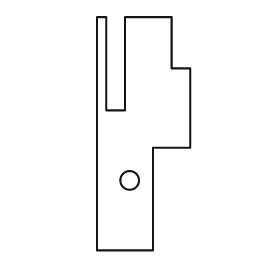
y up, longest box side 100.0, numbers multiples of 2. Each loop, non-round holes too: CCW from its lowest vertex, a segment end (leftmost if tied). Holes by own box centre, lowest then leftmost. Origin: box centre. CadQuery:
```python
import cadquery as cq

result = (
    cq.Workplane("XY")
    .moveTo(-20.0, -50.0)
    .lineTo(4.0, -50.0)
    .lineTo(4.0, -6.0)
    .lineTo(20.0, -6.0)
    .lineTo(20.0, 28.0)
    .lineTo(12.0, 28.0)
    .lineTo(12.0, 50.0)
    .lineTo(-8.0, 50.0)
    .lineTo(-8.0, 10.0)
    .lineTo(-16.0, 10.0)
    .lineTo(-16.0, 50.0)
    .lineTo(-20.0, 50.0)
    .close()
    .moveTo(-6.0, -20.0)
    .circle(4.0)
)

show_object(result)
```